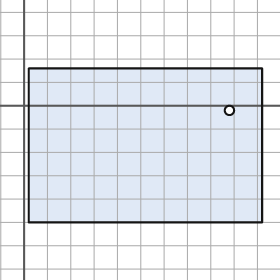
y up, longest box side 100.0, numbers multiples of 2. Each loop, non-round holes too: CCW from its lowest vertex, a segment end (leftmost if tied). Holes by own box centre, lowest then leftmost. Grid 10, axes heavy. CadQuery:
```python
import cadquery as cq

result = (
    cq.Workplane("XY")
    .moveTo(2.0, -50.0)
    .lineTo(102.0, -50.0)
    .lineTo(102.0, 16.0)
    .lineTo(2.0, 16.0)
    .close()
    .moveTo(88.0, -2.0)
    .circle(2.0)
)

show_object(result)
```